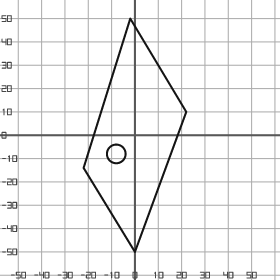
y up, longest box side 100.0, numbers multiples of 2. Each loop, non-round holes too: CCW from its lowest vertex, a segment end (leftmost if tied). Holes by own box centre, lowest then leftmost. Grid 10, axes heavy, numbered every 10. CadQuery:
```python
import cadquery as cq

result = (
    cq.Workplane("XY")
    .moveTo(0.0, -50.0)
    .lineTo(22.0, 10.0)
    .lineTo(-2.0, 50.0)
    .lineTo(-22.0, -14.0)
    .close()
    .moveTo(-8.0, -8.0)
    .circle(4.0)
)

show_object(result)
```